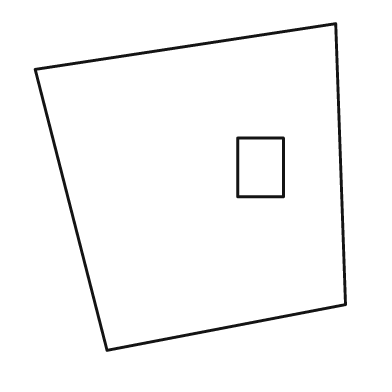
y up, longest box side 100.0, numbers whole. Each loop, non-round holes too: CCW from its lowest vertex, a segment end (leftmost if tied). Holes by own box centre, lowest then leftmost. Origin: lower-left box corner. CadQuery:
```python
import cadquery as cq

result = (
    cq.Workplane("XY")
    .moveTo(22.0, 0.0)
    .lineTo(95.0, 14.0)
    .lineTo(92.0, 100.0)
    .lineTo(0.0, 86.0)
    .close()
    .moveTo(62.0, 47.0)
    .lineTo(76.0, 47.0)
    .lineTo(76.0, 65.0)
    .lineTo(62.0, 65.0)
    .close()
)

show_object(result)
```